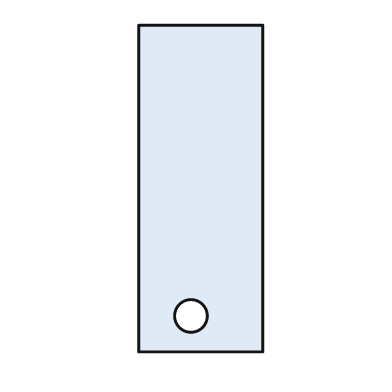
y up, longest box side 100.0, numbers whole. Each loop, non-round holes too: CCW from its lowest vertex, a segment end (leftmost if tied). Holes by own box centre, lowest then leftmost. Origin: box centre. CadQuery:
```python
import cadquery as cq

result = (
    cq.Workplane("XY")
    .moveTo(-19.0, -50.0)
    .lineTo(19.0, -50.0)
    .lineTo(19.0, 50.0)
    .lineTo(-19.0, 50.0)
    .close()
    .moveTo(-3.0, -39.0)
    .circle(5.0)
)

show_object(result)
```